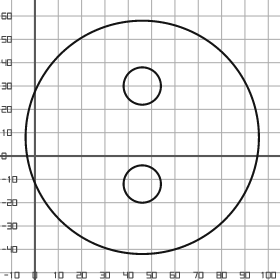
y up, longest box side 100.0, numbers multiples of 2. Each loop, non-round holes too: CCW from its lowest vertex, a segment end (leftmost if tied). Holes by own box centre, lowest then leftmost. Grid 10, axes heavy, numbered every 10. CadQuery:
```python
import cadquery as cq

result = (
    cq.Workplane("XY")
    .moveTo(46.0, 8.0)
    .circle(50.0)
    .moveTo(46.0, -12.0)
    .circle(8.0)
    .moveTo(46.0, 30.0)
    .circle(8.0)
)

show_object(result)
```